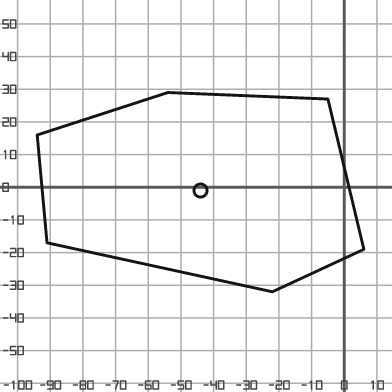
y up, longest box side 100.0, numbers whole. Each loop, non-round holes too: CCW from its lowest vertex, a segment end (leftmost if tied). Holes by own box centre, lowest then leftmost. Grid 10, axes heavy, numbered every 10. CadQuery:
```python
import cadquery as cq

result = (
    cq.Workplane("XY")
    .moveTo(-22.0, -32.0)
    .lineTo(6.0, -19.0)
    .lineTo(-5.0, 27.0)
    .lineTo(-54.0, 29.0)
    .lineTo(-94.0, 16.0)
    .lineTo(-91.0, -17.0)
    .close()
    .moveTo(-44.0, -1.0)
    .circle(2.0)
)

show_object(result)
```